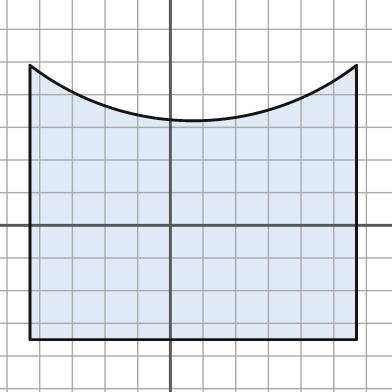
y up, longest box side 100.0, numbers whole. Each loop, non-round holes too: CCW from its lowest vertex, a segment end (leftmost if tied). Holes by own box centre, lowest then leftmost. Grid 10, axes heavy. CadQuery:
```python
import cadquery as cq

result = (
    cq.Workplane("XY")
    .moveTo(-43.0, -35.0)
    .lineTo(57.0, -35.0)
    .lineTo(57.0, 49.0)
    .threePointArc((7.0, 32.0), (-43.0, 49.0))
    .close()
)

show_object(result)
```